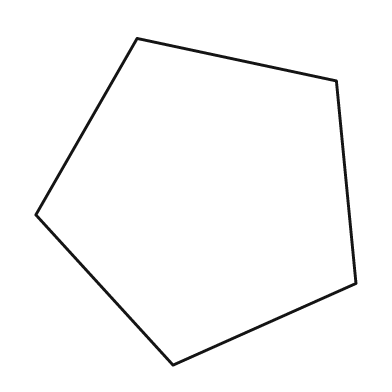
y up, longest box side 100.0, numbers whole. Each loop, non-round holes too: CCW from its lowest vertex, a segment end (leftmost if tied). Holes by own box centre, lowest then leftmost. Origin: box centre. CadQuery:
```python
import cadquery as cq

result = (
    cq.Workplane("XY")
    .moveTo(-7.0, -50.0)
    .lineTo(49.0, -25.0)
    .lineTo(43.0, 37.0)
    .lineTo(-18.0, 50.0)
    .lineTo(-49.0, -4.0)
    .close()
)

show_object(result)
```